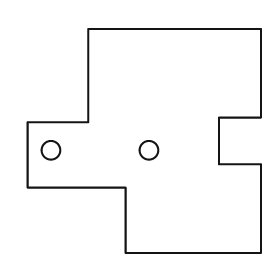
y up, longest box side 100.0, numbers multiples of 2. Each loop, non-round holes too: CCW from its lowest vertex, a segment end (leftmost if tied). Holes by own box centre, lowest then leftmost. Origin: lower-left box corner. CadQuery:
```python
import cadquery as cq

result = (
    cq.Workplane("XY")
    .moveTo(42.0, 0.0)
    .lineTo(100.0, 0.0)
    .lineTo(100.0, 38.0)
    .lineTo(82.0, 38.0)
    .lineTo(82.0, 58.0)
    .lineTo(100.0, 58.0)
    .lineTo(100.0, 96.0)
    .lineTo(26.0, 96.0)
    .lineTo(26.0, 56.0)
    .lineTo(0.0, 56.0)
    .lineTo(0.0, 28.0)
    .lineTo(42.0, 28.0)
    .close()
    .moveTo(10.0, 44.0)
    .circle(4.0)
    .moveTo(52.0, 44.0)
    .circle(4.0)
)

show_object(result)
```